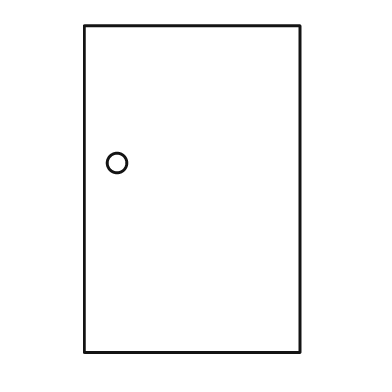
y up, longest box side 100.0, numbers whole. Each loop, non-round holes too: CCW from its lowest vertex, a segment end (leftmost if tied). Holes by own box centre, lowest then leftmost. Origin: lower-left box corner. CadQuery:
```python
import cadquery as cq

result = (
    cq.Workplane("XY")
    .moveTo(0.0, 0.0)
    .lineTo(66.0, 0.0)
    .lineTo(66.0, 100.0)
    .lineTo(0.0, 100.0)
    .close()
    .moveTo(10.0, 58.0)
    .circle(3.0)
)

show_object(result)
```